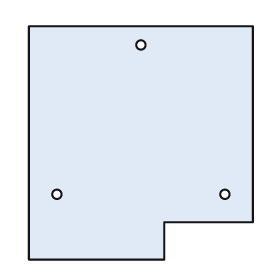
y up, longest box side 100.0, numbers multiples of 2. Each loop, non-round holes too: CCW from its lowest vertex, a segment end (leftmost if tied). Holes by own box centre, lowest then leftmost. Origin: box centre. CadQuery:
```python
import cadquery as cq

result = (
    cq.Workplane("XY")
    .moveTo(-48.0, -50.0)
    .lineTo(10.0, -50.0)
    .lineTo(10.0, -34.0)
    .lineTo(48.0, -34.0)
    .lineTo(48.0, 50.0)
    .lineTo(-48.0, 50.0)
    .close()
    .moveTo(-36.0, -22.0)
    .circle(2.0)
    .moveTo(36.0, -22.0)
    .circle(2.0)
    .moveTo(0.0, 42.0)
    .circle(2.0)
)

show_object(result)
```